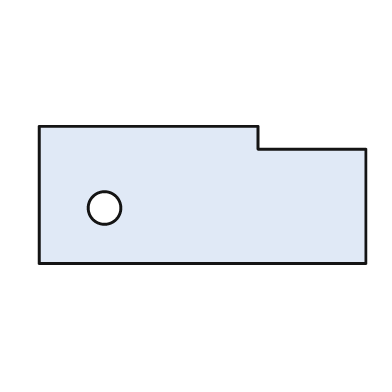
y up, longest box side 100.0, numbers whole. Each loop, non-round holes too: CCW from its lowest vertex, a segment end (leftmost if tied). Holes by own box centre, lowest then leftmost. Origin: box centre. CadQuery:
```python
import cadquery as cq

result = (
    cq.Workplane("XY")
    .moveTo(-50.0, -21.0)
    .lineTo(50.0, -21.0)
    .lineTo(50.0, 14.0)
    .lineTo(17.0, 14.0)
    .lineTo(17.0, 21.0)
    .lineTo(-50.0, 21.0)
    .close()
    .moveTo(-30.0, -4.0)
    .circle(5.0)
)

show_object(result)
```